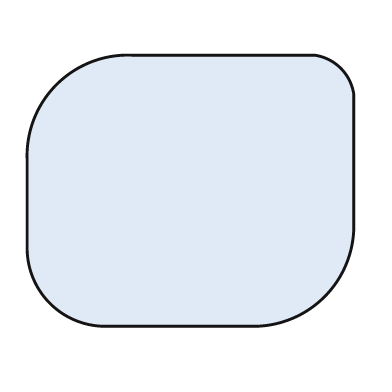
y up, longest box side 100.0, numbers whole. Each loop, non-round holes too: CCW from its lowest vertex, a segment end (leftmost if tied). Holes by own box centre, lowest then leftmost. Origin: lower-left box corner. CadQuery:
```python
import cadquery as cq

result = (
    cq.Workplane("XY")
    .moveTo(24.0, 0.0)
    .lineTo(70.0, 0.0)
    .threePointArc((91.0, 9.0), (100.0, 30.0))
    .lineTo(100.0, 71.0)
    .threePointArc((96.0, 79.0), (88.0, 83.0))
    .lineTo(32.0, 83.0)
    .threePointArc((9.0, 74.0), (0.0, 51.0))
    .lineTo(0.0, 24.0)
    .threePointArc((7.0, 7.0), (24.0, 0.0))
    .close()
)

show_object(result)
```